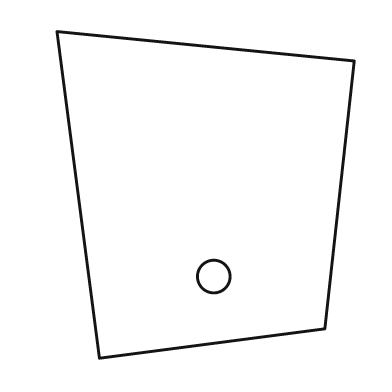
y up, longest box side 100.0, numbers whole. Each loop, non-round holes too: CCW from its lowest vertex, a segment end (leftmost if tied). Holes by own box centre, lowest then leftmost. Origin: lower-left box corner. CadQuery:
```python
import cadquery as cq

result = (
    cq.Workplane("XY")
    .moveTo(13.0, 0.0)
    .lineTo(82.0, 9.0)
    .lineTo(91.0, 91.0)
    .lineTo(0.0, 100.0)
    .close()
    .moveTo(48.0, 25.0)
    .circle(5.0)
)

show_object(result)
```